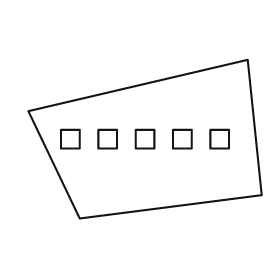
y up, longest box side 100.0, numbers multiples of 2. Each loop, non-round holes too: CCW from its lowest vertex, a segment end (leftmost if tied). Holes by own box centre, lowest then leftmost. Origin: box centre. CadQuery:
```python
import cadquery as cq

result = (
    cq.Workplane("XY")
    .moveTo(-28.0, -34.0)
    .lineTo(50.0, -24.0)
    .lineTo(44.0, 34.0)
    .lineTo(-50.0, 12.0)
    .close()
    .moveTo(-36.0, -4.0)
    .lineTo(-28.0, -4.0)
    .lineTo(-28.0, 4.0)
    .lineTo(-36.0, 4.0)
    .close()
    .moveTo(-20.0, -4.0)
    .lineTo(-12.0, -4.0)
    .lineTo(-12.0, 4.0)
    .lineTo(-20.0, 4.0)
    .close()
    .moveTo(-4.0, -4.0)
    .lineTo(4.0, -4.0)
    .lineTo(4.0, 4.0)
    .lineTo(-4.0, 4.0)
    .close()
    .moveTo(12.0, -4.0)
    .lineTo(20.0, -4.0)
    .lineTo(20.0, 4.0)
    .lineTo(12.0, 4.0)
    .close()
    .moveTo(28.0, -4.0)
    .lineTo(36.0, -4.0)
    .lineTo(36.0, 4.0)
    .lineTo(28.0, 4.0)
    .close()
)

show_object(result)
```